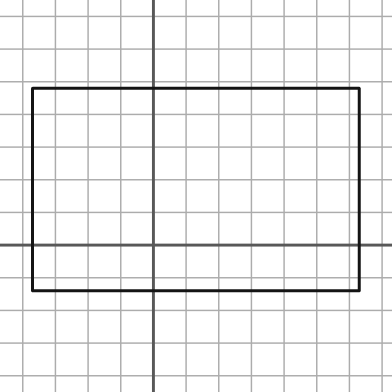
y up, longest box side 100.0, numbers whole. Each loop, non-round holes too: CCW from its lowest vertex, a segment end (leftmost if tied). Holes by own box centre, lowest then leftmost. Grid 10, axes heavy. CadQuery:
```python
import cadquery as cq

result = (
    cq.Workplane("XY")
    .moveTo(-37.0, -14.0)
    .lineTo(63.0, -14.0)
    .lineTo(63.0, 48.0)
    .lineTo(-37.0, 48.0)
    .close()
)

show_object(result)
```